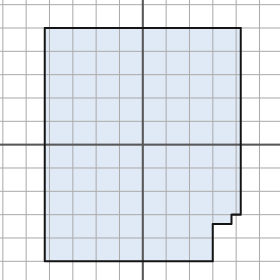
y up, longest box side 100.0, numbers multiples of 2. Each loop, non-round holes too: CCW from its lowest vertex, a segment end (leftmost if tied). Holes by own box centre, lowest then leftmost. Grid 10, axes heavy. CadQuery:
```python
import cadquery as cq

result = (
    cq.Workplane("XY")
    .moveTo(-42.0, -50.0)
    .lineTo(30.0, -50.0)
    .lineTo(30.0, -34.0)
    .lineTo(38.0, -34.0)
    .lineTo(38.0, -30.0)
    .lineTo(42.0, -30.0)
    .lineTo(42.0, 50.0)
    .lineTo(-42.0, 50.0)
    .close()
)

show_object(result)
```